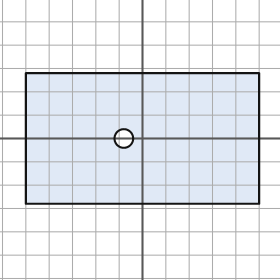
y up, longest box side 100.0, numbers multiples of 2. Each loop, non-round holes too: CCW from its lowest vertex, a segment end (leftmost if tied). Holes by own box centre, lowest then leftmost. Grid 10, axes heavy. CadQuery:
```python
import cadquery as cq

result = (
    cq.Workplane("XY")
    .moveTo(-50.0, -28.0)
    .lineTo(50.0, -28.0)
    .lineTo(50.0, 28.0)
    .lineTo(-50.0, 28.0)
    .close()
    .moveTo(-8.0, 0.0)
    .circle(4.0)
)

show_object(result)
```